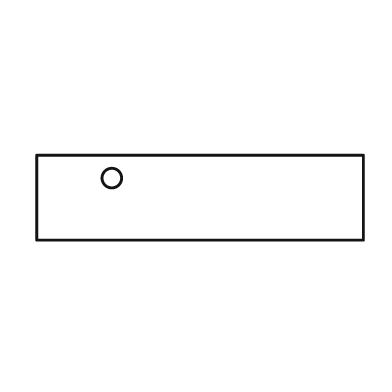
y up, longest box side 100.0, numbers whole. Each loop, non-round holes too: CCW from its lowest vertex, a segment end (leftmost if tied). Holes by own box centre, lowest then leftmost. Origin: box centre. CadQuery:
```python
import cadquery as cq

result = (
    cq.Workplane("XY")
    .moveTo(-50.0, -13.0)
    .lineTo(50.0, -13.0)
    .lineTo(50.0, 13.0)
    .lineTo(-50.0, 13.0)
    .close()
    .moveTo(-27.0, 6.0)
    .circle(3.0)
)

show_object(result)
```